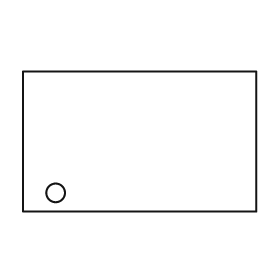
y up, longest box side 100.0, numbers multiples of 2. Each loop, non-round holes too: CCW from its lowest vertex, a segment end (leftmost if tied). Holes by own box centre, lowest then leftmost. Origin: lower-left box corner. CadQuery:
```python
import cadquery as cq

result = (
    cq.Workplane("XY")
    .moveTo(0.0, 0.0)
    .lineTo(100.0, 0.0)
    .lineTo(100.0, 60.0)
    .lineTo(0.0, 60.0)
    .close()
    .moveTo(14.0, 8.0)
    .circle(4.0)
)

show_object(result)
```